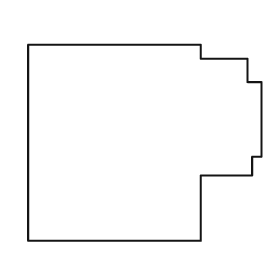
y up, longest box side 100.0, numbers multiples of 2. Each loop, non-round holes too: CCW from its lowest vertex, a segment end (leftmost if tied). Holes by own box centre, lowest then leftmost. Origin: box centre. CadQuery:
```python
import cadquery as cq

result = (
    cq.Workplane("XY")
    .moveTo(-50.0, -42.0)
    .lineTo(24.0, -42.0)
    .lineTo(24.0, -14.0)
    .lineTo(46.0, -14.0)
    .lineTo(46.0, -6.0)
    .lineTo(50.0, -6.0)
    .lineTo(50.0, 26.0)
    .lineTo(44.0, 26.0)
    .lineTo(44.0, 36.0)
    .lineTo(24.0, 36.0)
    .lineTo(24.0, 42.0)
    .lineTo(-50.0, 42.0)
    .close()
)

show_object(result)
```